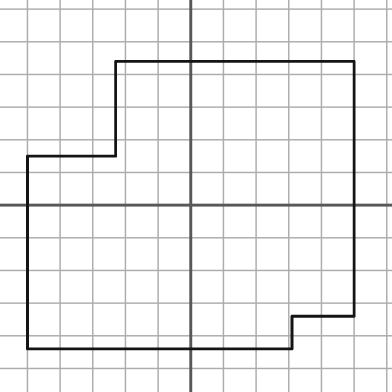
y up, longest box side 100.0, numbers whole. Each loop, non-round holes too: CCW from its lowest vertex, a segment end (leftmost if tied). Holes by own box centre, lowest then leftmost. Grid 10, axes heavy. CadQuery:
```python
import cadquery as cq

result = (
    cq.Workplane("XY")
    .moveTo(-50.0, -44.0)
    .lineTo(31.0, -44.0)
    .lineTo(31.0, -34.0)
    .lineTo(50.0, -34.0)
    .lineTo(50.0, 44.0)
    .lineTo(-23.0, 44.0)
    .lineTo(-23.0, 15.0)
    .lineTo(-50.0, 15.0)
    .close()
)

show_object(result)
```